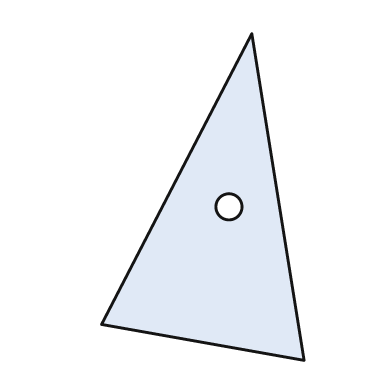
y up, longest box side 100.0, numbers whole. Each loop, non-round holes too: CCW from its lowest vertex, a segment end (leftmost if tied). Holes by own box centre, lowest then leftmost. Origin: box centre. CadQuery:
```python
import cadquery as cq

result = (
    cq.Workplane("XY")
    .moveTo(31.0, -50.0)
    .lineTo(15.0, 50.0)
    .lineTo(-31.0, -39.0)
    .close()
    .moveTo(8.0, -3.0)
    .circle(4.0)
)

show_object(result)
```